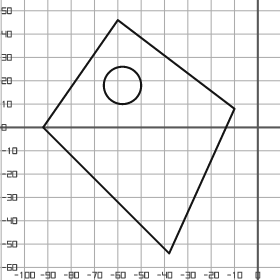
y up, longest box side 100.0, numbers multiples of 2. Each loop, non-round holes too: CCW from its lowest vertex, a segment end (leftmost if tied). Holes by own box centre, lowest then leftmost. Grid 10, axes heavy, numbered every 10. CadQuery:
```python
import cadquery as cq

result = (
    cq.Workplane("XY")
    .moveTo(-38.0, -54.0)
    .lineTo(-10.0, 8.0)
    .lineTo(-60.0, 46.0)
    .lineTo(-92.0, 0.0)
    .close()
    .moveTo(-58.0, 18.0)
    .circle(8.0)
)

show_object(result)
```